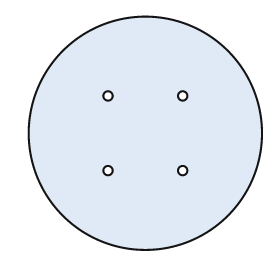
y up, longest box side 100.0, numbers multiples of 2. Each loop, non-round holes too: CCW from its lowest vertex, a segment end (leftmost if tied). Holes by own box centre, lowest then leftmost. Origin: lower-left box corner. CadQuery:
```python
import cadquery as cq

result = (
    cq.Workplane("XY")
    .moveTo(50.0, 50.0)
    .circle(50.0)
    .moveTo(34.0, 34.0)
    .circle(2.0)
    .moveTo(66.0, 34.0)
    .circle(2.0)
    .moveTo(34.0, 66.0)
    .circle(2.0)
    .moveTo(66.0, 66.0)
    .circle(2.0)
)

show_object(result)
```